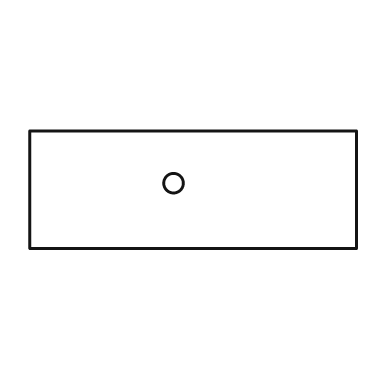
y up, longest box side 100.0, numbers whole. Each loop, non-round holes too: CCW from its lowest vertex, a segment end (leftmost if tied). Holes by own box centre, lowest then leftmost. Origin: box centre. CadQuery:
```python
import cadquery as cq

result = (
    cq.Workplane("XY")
    .moveTo(-50.0, -18.0)
    .lineTo(50.0, -18.0)
    .lineTo(50.0, 18.0)
    .lineTo(-50.0, 18.0)
    .close()
    .moveTo(-6.0, 2.0)
    .circle(3.0)
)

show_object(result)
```